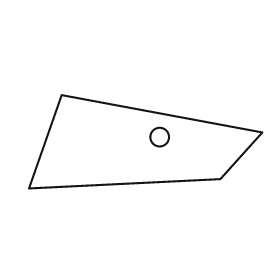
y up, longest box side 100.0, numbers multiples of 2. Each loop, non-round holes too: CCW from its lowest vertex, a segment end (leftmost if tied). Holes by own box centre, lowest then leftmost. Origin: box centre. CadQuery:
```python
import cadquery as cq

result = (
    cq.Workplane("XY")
    .moveTo(-50.0, -20.0)
    .lineTo(32.0, -16.0)
    .lineTo(50.0, 4.0)
    .lineTo(-36.0, 20.0)
    .close()
    .moveTo(6.0, 2.0)
    .circle(4.0)
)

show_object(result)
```